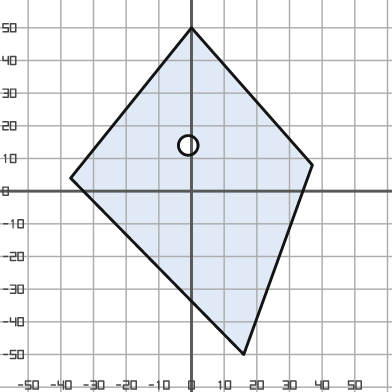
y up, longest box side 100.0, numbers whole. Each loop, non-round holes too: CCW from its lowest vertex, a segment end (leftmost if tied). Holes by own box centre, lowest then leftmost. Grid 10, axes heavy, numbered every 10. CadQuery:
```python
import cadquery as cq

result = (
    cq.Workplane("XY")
    .moveTo(16.0, -50.0)
    .lineTo(37.0, 8.0)
    .lineTo(0.0, 50.0)
    .lineTo(-37.0, 4.0)
    .close()
    .moveTo(-1.0, 14.0)
    .circle(3.0)
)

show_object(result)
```